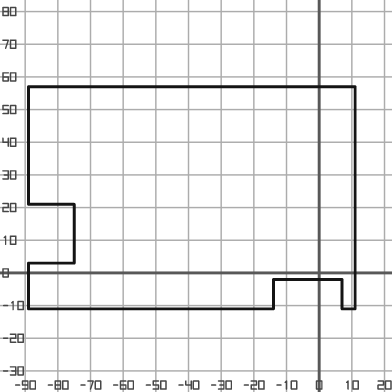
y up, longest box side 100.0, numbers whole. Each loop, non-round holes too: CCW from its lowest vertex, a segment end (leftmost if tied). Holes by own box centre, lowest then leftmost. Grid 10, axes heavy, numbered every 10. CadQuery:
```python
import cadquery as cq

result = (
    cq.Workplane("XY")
    .moveTo(-89.0, -11.0)
    .lineTo(-14.0, -11.0)
    .lineTo(-14.0, -2.0)
    .lineTo(7.0, -2.0)
    .lineTo(7.0, -11.0)
    .lineTo(11.0, -11.0)
    .lineTo(11.0, 57.0)
    .lineTo(-89.0, 57.0)
    .lineTo(-89.0, 21.0)
    .lineTo(-75.0, 21.0)
    .lineTo(-75.0, 3.0)
    .lineTo(-89.0, 3.0)
    .close()
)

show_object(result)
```